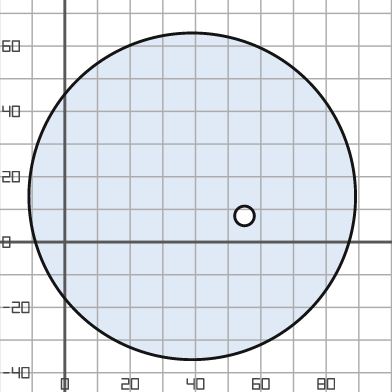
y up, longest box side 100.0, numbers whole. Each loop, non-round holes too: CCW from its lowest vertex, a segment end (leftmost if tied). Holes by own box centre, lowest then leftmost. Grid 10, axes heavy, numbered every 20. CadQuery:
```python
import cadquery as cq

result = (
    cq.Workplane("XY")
    .moveTo(39.0, 14.0)
    .circle(50.0)
    .moveTo(55.0, 8.0)
    .circle(3.0)
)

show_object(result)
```